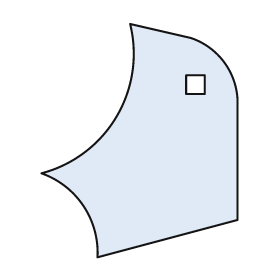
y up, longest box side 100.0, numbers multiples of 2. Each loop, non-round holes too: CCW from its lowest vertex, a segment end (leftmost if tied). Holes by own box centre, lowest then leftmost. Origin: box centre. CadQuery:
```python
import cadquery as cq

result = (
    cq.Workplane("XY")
    .moveTo(-18.0, -50.0)
    .lineTo(42.0, -34.0)
    .lineTo(42.0, 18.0)
    .threePointArc((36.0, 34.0), (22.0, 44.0))
    .lineTo(-4.0, 50.0)
    .threePointArc((-10.0, 10.0), (-42.0, -14.0))
    .threePointArc((-24.0, -28.0), (-18.0, -50.0))
    .close()
    .moveTo(20.0, 20.0)
    .lineTo(28.0, 20.0)
    .lineTo(28.0, 28.0)
    .lineTo(20.0, 28.0)
    .close()
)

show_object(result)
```